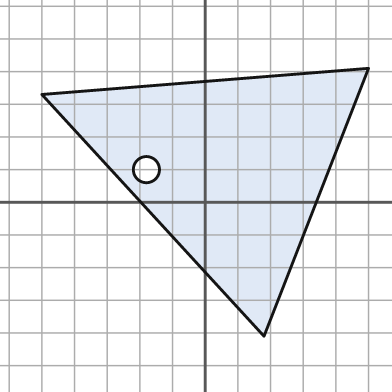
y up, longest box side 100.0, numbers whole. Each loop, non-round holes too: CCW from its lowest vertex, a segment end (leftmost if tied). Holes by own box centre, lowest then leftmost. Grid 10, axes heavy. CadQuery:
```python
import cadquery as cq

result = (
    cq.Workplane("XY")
    .moveTo(18.0, -41.0)
    .lineTo(50.0, 41.0)
    .lineTo(-50.0, 33.0)
    .close()
    .moveTo(-18.0, 10.0)
    .circle(4.0)
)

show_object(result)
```